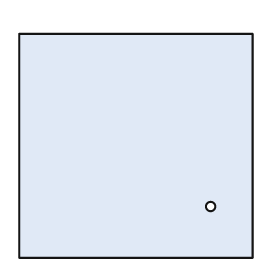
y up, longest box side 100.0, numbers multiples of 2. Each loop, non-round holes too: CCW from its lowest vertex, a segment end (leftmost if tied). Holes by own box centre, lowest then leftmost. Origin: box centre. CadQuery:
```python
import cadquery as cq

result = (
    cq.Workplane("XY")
    .moveTo(-50.0, -48.0)
    .lineTo(50.0, -48.0)
    .lineTo(50.0, 48.0)
    .lineTo(-50.0, 48.0)
    .close()
    .moveTo(32.0, -26.0)
    .circle(2.0)
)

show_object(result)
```